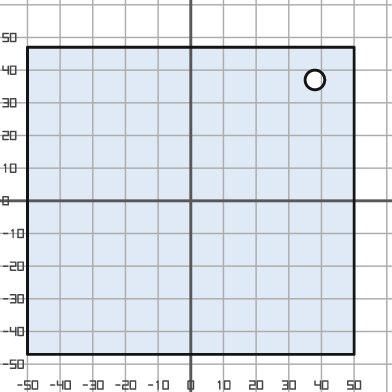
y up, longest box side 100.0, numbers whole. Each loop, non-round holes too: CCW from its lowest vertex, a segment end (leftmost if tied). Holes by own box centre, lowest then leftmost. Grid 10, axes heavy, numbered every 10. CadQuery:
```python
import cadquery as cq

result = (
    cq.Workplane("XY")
    .moveTo(-50.0, -47.0)
    .lineTo(50.0, -47.0)
    .lineTo(50.0, 47.0)
    .lineTo(-50.0, 47.0)
    .close()
    .moveTo(38.0, 37.0)
    .circle(3.0)
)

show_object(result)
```